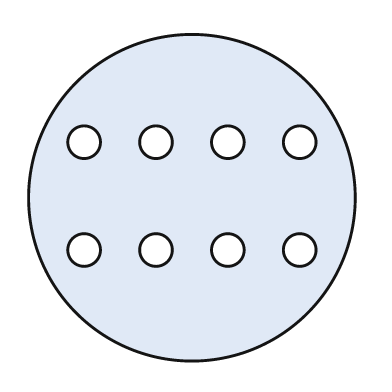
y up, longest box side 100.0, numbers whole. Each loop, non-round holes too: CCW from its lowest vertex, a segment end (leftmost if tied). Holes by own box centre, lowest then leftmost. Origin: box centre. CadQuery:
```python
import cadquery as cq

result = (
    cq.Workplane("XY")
    .moveTo(0.0, 0.0)
    .circle(50.0)
    .moveTo(-33.0, -16.0)
    .circle(5.0)
    .moveTo(-11.0, -16.0)
    .circle(5.0)
    .moveTo(11.0, -16.0)
    .circle(5.0)
    .moveTo(33.0, -16.0)
    .circle(5.0)
    .moveTo(-33.0, 17.0)
    .circle(5.0)
    .moveTo(-11.0, 17.0)
    .circle(5.0)
    .moveTo(11.0, 17.0)
    .circle(5.0)
    .moveTo(33.0, 17.0)
    .circle(5.0)
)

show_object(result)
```